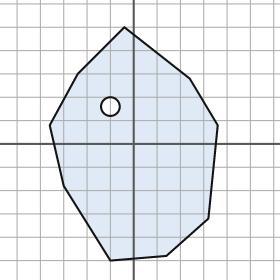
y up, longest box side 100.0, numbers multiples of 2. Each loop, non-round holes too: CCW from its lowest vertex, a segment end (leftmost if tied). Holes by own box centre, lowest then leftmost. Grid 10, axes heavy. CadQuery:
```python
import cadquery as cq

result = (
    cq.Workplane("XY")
    .moveTo(-10.0, -50.0)
    .lineTo(14.0, -48.0)
    .lineTo(32.0, -32.0)
    .lineTo(36.0, 8.0)
    .lineTo(24.0, 28.0)
    .lineTo(-4.0, 50.0)
    .lineTo(-24.0, 30.0)
    .lineTo(-36.0, 8.0)
    .lineTo(-30.0, -18.0)
    .close()
    .moveTo(-10.0, 16.0)
    .circle(4.0)
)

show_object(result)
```